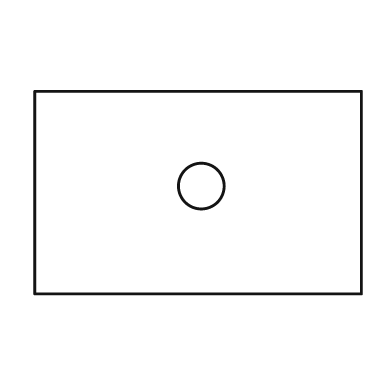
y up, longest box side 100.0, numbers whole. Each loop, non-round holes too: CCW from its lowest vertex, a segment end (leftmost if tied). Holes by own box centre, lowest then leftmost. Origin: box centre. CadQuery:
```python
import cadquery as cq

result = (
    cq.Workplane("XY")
    .moveTo(-50.0, -31.0)
    .lineTo(50.0, -31.0)
    .lineTo(50.0, 31.0)
    .lineTo(-50.0, 31.0)
    .close()
    .moveTo(1.0, 2.0)
    .circle(7.0)
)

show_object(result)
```